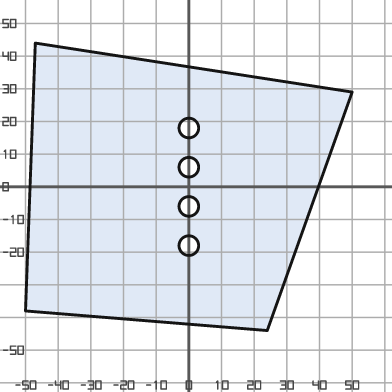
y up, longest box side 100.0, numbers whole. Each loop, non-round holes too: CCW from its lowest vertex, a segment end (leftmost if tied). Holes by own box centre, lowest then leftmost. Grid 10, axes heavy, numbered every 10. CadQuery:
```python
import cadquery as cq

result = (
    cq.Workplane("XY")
    .moveTo(24.0, -44.0)
    .lineTo(50.0, 29.0)
    .lineTo(-47.0, 44.0)
    .lineTo(-50.0, -38.0)
    .close()
    .moveTo(0.0, -18.0)
    .circle(3.0)
    .moveTo(0.0, -6.0)
    .circle(3.0)
    .moveTo(0.0, 6.0)
    .circle(3.0)
    .moveTo(0.0, 18.0)
    .circle(3.0)
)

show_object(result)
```